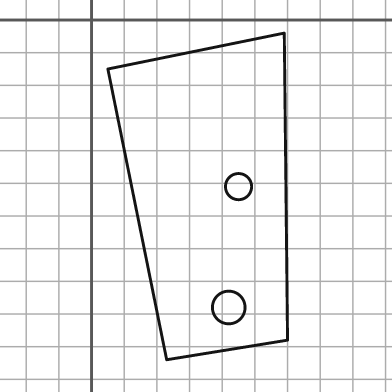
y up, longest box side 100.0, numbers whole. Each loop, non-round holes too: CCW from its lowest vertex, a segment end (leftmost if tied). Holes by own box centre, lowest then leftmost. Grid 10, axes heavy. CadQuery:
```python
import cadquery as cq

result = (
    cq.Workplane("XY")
    .moveTo(23.0, -104.0)
    .lineTo(60.0, -98.0)
    .lineTo(59.0, -4.0)
    .lineTo(5.0, -15.0)
    .close()
    .moveTo(42.0, -88.0)
    .circle(5.0)
    .moveTo(45.0, -51.0)
    .circle(4.0)
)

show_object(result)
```